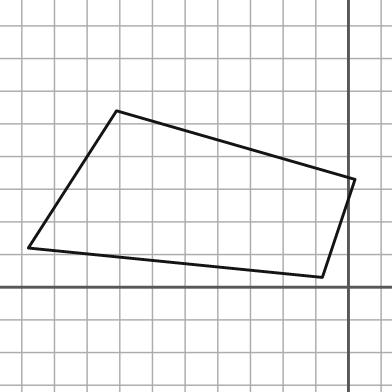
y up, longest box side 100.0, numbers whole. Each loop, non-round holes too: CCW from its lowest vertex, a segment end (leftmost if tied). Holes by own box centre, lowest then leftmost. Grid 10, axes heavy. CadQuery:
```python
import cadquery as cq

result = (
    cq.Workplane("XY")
    .moveTo(-8.0, 3.0)
    .lineTo(2.0, 33.0)
    .lineTo(-71.0, 54.0)
    .lineTo(-98.0, 12.0)
    .close()
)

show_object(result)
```